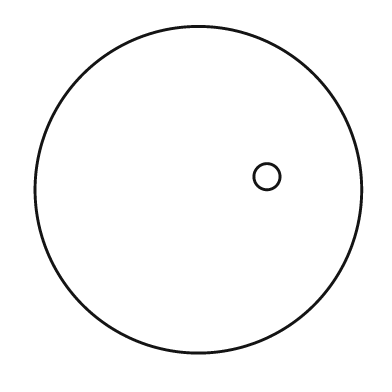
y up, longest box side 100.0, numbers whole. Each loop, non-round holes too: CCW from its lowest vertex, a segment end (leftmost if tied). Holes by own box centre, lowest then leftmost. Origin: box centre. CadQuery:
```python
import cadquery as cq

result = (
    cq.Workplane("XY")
    .moveTo(0.0, 0.0)
    .circle(50.0)
    .moveTo(21.0, 4.0)
    .circle(4.0)
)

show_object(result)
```